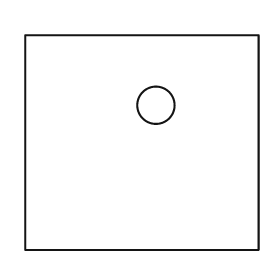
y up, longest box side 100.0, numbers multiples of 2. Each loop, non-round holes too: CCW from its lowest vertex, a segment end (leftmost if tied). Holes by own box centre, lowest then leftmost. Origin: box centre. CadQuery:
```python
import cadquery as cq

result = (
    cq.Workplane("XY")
    .moveTo(-50.0, -46.0)
    .lineTo(50.0, -46.0)
    .lineTo(50.0, 46.0)
    .lineTo(-50.0, 46.0)
    .close()
    .moveTo(6.0, 16.0)
    .circle(8.0)
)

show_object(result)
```